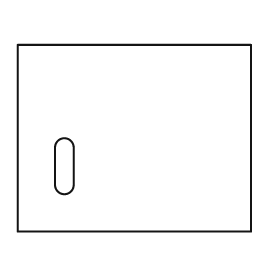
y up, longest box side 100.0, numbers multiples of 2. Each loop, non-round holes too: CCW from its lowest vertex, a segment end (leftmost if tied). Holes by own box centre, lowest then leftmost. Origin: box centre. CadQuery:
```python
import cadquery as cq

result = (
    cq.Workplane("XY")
    .moveTo(-50.0, -40.0)
    .lineTo(50.0, -40.0)
    .lineTo(50.0, 40.0)
    .lineTo(-50.0, 40.0)
    .close()
    .moveTo(-34.0, -20.0)
    .threePointArc((-30.0, -24.0), (-26.0, -20.0))
    .lineTo(-26.0, -4.0)
    .threePointArc((-30.0, 0.0), (-34.0, -4.0))
    .close()
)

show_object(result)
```